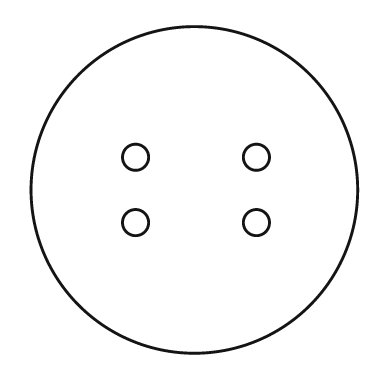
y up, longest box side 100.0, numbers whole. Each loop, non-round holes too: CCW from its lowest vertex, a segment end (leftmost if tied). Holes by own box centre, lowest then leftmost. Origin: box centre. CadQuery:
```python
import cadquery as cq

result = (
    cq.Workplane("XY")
    .moveTo(0.0, 0.0)
    .circle(50.0)
    .moveTo(-18.0, -10.0)
    .circle(4.0)
    .moveTo(19.0, -10.0)
    .circle(4.0)
    .moveTo(-18.0, 10.0)
    .circle(4.0)
    .moveTo(19.0, 10.0)
    .circle(4.0)
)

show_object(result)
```